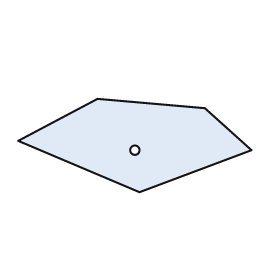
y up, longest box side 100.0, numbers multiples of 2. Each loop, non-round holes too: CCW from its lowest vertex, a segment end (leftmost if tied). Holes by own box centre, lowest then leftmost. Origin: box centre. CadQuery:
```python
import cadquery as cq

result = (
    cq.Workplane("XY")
    .moveTo(2.0, -20.0)
    .lineTo(50.0, -2.0)
    .lineTo(30.0, 16.0)
    .lineTo(-16.0, 20.0)
    .lineTo(-50.0, 2.0)
    .close()
    .moveTo(0.0, -2.0)
    .circle(2.0)
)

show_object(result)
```